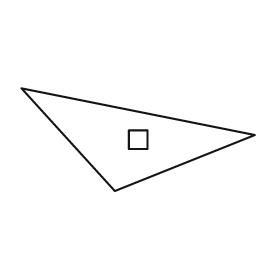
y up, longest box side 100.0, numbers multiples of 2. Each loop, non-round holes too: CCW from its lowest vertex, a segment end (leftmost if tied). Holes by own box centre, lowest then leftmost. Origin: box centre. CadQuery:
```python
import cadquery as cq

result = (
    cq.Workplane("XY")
    .moveTo(-10.0, -22.0)
    .lineTo(50.0, 2.0)
    .lineTo(-50.0, 22.0)
    .close()
    .moveTo(-4.0, -4.0)
    .lineTo(4.0, -4.0)
    .lineTo(4.0, 4.0)
    .lineTo(-4.0, 4.0)
    .close()
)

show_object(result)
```